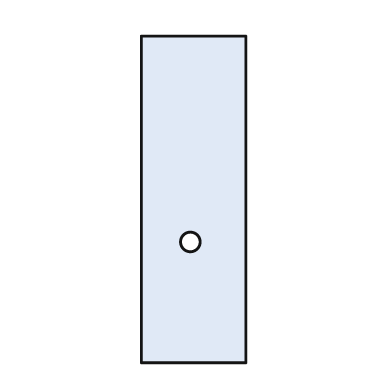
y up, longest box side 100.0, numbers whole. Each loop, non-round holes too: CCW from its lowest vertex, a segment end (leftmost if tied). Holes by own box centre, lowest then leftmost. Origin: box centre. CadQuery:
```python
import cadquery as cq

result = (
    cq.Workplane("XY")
    .moveTo(-16.0, -50.0)
    .lineTo(16.0, -50.0)
    .lineTo(16.0, 50.0)
    .lineTo(-16.0, 50.0)
    .close()
    .moveTo(-1.0, -13.0)
    .circle(3.0)
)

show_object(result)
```